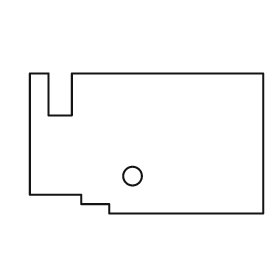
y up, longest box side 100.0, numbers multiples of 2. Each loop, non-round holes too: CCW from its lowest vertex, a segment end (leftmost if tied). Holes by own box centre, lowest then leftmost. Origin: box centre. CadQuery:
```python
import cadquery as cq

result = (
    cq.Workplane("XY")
    .moveTo(-16.0, -30.0)
    .lineTo(50.0, -30.0)
    .lineTo(50.0, 30.0)
    .lineTo(-32.0, 30.0)
    .lineTo(-32.0, 12.0)
    .lineTo(-42.0, 12.0)
    .lineTo(-42.0, 30.0)
    .lineTo(-50.0, 30.0)
    .lineTo(-50.0, -22.0)
    .lineTo(-28.0, -22.0)
    .lineTo(-28.0, -26.0)
    .lineTo(-16.0, -26.0)
    .close()
    .moveTo(-6.0, -14.0)
    .circle(4.0)
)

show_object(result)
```